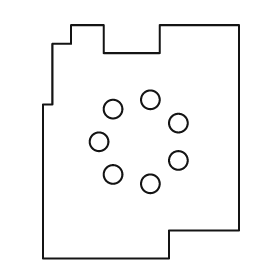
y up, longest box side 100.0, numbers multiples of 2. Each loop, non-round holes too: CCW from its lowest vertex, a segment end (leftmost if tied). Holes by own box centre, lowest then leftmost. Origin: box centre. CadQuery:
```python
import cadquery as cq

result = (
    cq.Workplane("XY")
    .moveTo(-42.0, -50.0)
    .lineTo(12.0, -50.0)
    .lineTo(12.0, -38.0)
    .lineTo(42.0, -38.0)
    .lineTo(42.0, 50.0)
    .lineTo(8.0, 50.0)
    .lineTo(8.0, 38.0)
    .lineTo(-16.0, 38.0)
    .lineTo(-16.0, 50.0)
    .lineTo(-30.0, 50.0)
    .lineTo(-30.0, 42.0)
    .lineTo(-38.0, 42.0)
    .lineTo(-38.0, 16.0)
    .lineTo(-42.0, 16.0)
    .close()
    .moveTo(4.0, -18.0)
    .circle(4.0)
    .moveTo(-12.0, -14.0)
    .circle(4.0)
    .moveTo(16.0, -8.0)
    .circle(4.0)
    .moveTo(-18.0, 0.0)
    .circle(4.0)
    .moveTo(16.0, 8.0)
    .circle(4.0)
    .moveTo(-12.0, 14.0)
    .circle(4.0)
    .moveTo(4.0, 18.0)
    .circle(4.0)
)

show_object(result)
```